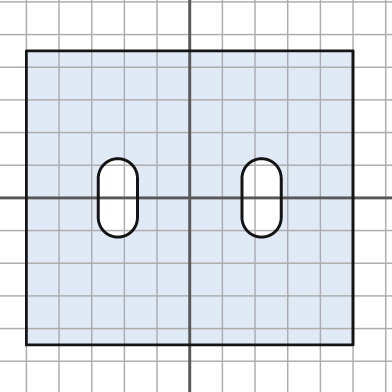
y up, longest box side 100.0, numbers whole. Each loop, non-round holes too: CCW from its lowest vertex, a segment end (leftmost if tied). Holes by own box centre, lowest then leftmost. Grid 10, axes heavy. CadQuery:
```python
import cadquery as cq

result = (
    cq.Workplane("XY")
    .moveTo(-50.0, -45.0)
    .lineTo(50.0, -45.0)
    .lineTo(50.0, 45.0)
    .lineTo(-50.0, 45.0)
    .close()
    .moveTo(-28.0, -6.0)
    .threePointArc((-22.0, -12.0), (-16.0, -6.0))
    .lineTo(-16.0, 6.0)
    .threePointArc((-22.0, 12.0), (-28.0, 6.0))
    .close()
    .moveTo(16.0, -6.0)
    .threePointArc((22.0, -12.0), (28.0, -6.0))
    .lineTo(28.0, 6.0)
    .threePointArc((22.0, 12.0), (16.0, 6.0))
    .close()
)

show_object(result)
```